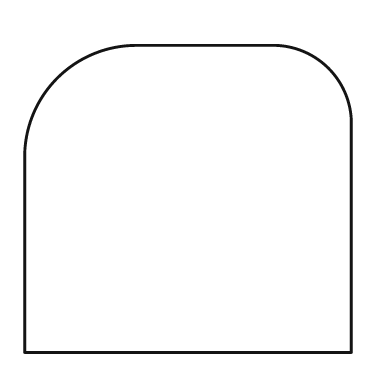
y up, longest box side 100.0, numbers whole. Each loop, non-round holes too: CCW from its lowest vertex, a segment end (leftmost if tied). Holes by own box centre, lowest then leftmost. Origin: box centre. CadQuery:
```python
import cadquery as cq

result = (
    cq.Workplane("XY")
    .moveTo(-50.0, -47.0)
    .lineTo(50.0, -47.0)
    .lineTo(50.0, 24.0)
    .threePointArc((43.0, 40.0), (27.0, 47.0))
    .lineTo(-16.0, 47.0)
    .threePointArc((-40.0, 37.0), (-50.0, 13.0))
    .close()
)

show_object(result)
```